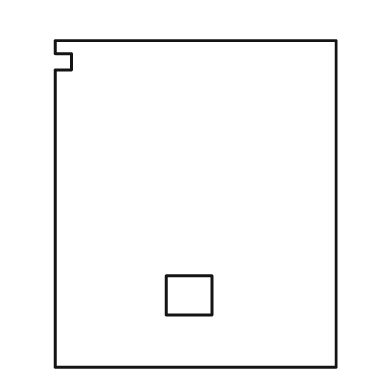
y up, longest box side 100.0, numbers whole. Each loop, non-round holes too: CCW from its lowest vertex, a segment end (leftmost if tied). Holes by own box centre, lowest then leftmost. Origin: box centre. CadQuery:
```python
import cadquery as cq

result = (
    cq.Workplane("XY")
    .moveTo(-43.0, -50.0)
    .lineTo(43.0, -50.0)
    .lineTo(43.0, 50.0)
    .lineTo(-43.0, 50.0)
    .lineTo(-43.0, 46.0)
    .lineTo(-38.0, 46.0)
    .lineTo(-38.0, 41.0)
    .lineTo(-43.0, 41.0)
    .close()
    .moveTo(-9.0, -34.0)
    .lineTo(5.0, -34.0)
    .lineTo(5.0, -22.0)
    .lineTo(-9.0, -22.0)
    .close()
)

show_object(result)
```